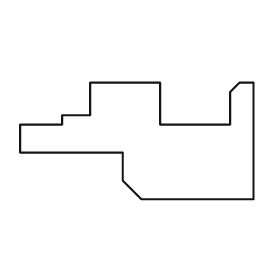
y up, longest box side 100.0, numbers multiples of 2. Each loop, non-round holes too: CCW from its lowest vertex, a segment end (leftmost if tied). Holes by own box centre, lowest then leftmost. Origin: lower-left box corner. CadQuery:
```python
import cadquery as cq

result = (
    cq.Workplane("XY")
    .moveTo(52.0, 0.0)
    .lineTo(100.0, 0.0)
    .lineTo(100.0, 50.0)
    .lineTo(94.0, 50.0)
    .lineTo(90.0, 46.0)
    .lineTo(90.0, 32.0)
    .lineTo(60.0, 32.0)
    .lineTo(60.0, 50.0)
    .lineTo(30.0, 50.0)
    .lineTo(30.0, 36.0)
    .lineTo(18.0, 36.0)
    .lineTo(18.0, 32.0)
    .lineTo(0.0, 32.0)
    .lineTo(0.0, 20.0)
    .lineTo(44.0, 20.0)
    .lineTo(44.0, 8.0)
    .close()
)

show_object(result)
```